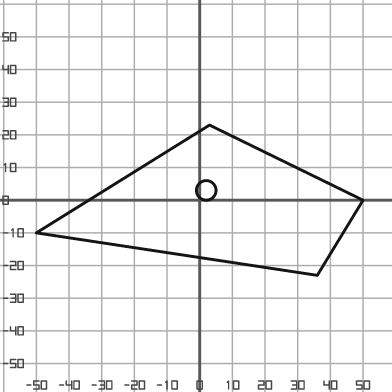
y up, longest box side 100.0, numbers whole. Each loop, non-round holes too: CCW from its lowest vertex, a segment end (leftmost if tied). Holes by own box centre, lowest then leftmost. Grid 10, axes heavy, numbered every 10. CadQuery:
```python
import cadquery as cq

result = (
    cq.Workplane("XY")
    .moveTo(36.0, -23.0)
    .lineTo(50.0, 0.0)
    .lineTo(3.0, 23.0)
    .lineTo(-50.0, -10.0)
    .close()
    .moveTo(2.0, 3.0)
    .circle(3.0)
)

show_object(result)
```